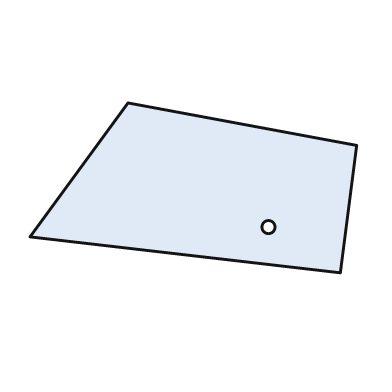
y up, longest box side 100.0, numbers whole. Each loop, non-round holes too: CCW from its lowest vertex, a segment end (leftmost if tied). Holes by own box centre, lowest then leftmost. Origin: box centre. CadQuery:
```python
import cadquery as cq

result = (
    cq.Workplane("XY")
    .moveTo(45.0, -26.0)
    .lineTo(50.0, 13.0)
    .lineTo(-20.0, 26.0)
    .lineTo(-50.0, -15.0)
    .close()
    .moveTo(23.0, -12.0)
    .circle(2.0)
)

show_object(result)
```